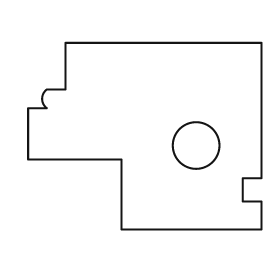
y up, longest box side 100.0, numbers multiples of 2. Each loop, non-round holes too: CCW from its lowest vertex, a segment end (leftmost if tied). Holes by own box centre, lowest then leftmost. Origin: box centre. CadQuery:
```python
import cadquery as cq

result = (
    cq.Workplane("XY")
    .moveTo(-10.0, -40.0)
    .lineTo(50.0, -40.0)
    .lineTo(50.0, -28.0)
    .lineTo(42.0, -28.0)
    .lineTo(42.0, -18.0)
    .lineTo(50.0, -18.0)
    .lineTo(50.0, 40.0)
    .lineTo(-34.0, 40.0)
    .lineTo(-34.0, 20.0)
    .lineTo(-42.0, 20.0)
    .threePointArc((-44.0, 16.0), (-42.0, 12.0))
    .lineTo(-50.0, 12.0)
    .lineTo(-50.0, -10.0)
    .lineTo(-10.0, -10.0)
    .close()
    .moveTo(22.0, -4.0)
    .circle(10.0)
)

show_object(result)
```